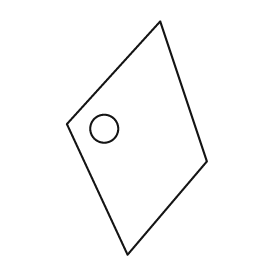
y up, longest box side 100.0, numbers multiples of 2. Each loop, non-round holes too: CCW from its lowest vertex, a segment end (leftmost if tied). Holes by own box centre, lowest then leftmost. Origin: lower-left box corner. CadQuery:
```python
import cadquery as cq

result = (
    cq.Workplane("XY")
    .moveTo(26.0, 0.0)
    .lineTo(60.0, 40.0)
    .lineTo(40.0, 100.0)
    .lineTo(0.0, 56.0)
    .close()
    .moveTo(16.0, 54.0)
    .circle(6.0)
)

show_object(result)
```